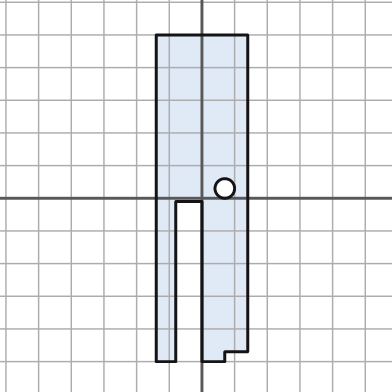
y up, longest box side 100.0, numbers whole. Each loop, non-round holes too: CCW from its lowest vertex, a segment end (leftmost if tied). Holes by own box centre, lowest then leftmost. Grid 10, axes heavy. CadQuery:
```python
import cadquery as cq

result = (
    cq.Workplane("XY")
    .moveTo(-14.0, -50.0)
    .lineTo(-8.0, -50.0)
    .lineTo(-8.0, -1.0)
    .lineTo(0.0, -1.0)
    .lineTo(0.0, -50.0)
    .lineTo(7.0, -50.0)
    .lineTo(7.0, -47.0)
    .lineTo(14.0, -47.0)
    .lineTo(14.0, 50.0)
    .lineTo(-14.0, 50.0)
    .close()
    .moveTo(7.0, 3.0)
    .circle(3.0)
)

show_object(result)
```